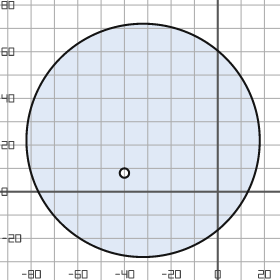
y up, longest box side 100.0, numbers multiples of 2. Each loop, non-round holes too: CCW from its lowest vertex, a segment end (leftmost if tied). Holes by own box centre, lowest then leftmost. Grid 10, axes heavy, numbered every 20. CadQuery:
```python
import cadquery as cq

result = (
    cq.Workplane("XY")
    .moveTo(-32.0, 22.0)
    .circle(50.0)
    .moveTo(-40.0, 8.0)
    .circle(2.0)
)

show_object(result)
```